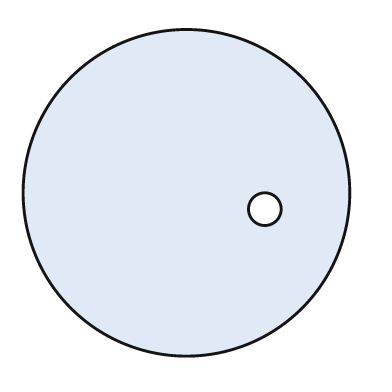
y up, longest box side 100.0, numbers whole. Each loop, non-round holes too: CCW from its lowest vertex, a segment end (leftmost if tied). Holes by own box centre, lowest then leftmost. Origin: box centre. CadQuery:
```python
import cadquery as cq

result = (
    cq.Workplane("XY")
    .moveTo(0.0, 0.0)
    .circle(50.0)
    .moveTo(24.0, -5.0)
    .circle(5.0)
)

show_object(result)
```